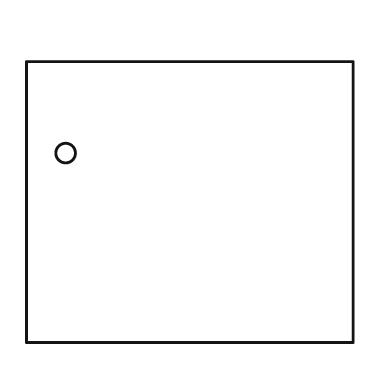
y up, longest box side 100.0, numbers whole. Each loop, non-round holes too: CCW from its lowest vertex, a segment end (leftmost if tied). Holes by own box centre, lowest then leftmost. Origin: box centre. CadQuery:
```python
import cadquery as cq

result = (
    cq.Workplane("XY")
    .moveTo(-50.0, -43.0)
    .lineTo(50.0, -43.0)
    .lineTo(50.0, 43.0)
    .lineTo(-50.0, 43.0)
    .close()
    .moveTo(-38.0, 15.0)
    .circle(3.0)
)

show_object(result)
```